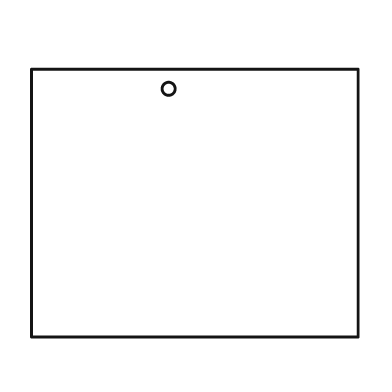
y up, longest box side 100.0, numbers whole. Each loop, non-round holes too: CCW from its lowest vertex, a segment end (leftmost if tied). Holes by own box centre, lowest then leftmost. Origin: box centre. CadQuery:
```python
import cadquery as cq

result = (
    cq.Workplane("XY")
    .moveTo(-50.0, -41.0)
    .lineTo(50.0, -41.0)
    .lineTo(50.0, 41.0)
    .lineTo(-50.0, 41.0)
    .close()
    .moveTo(-8.0, 35.0)
    .circle(2.0)
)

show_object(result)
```